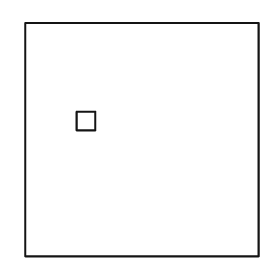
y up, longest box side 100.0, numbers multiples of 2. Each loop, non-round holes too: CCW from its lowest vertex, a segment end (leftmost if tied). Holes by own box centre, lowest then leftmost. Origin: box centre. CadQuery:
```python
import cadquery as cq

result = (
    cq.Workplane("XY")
    .moveTo(-50.0, -50.0)
    .lineTo(50.0, -50.0)
    .lineTo(50.0, 50.0)
    .lineTo(-50.0, 50.0)
    .close()
    .moveTo(-28.0, 4.0)
    .lineTo(-20.0, 4.0)
    .lineTo(-20.0, 12.0)
    .lineTo(-28.0, 12.0)
    .close()
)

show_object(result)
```